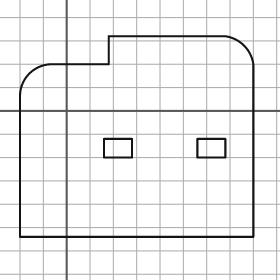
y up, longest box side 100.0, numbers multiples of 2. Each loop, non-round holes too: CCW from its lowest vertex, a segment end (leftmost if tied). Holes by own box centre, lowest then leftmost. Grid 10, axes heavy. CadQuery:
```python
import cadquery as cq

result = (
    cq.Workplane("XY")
    .moveTo(-20.0, -54.0)
    .lineTo(80.0, -54.0)
    .lineTo(80.0, 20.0)
    .threePointArc((76.0, 28.0), (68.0, 32.0))
    .lineTo(18.0, 32.0)
    .lineTo(18.0, 20.0)
    .lineTo(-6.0, 20.0)
    .threePointArc((-16.0, 16.0), (-20.0, 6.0))
    .close()
    .moveTo(16.0, -20.0)
    .lineTo(28.0, -20.0)
    .lineTo(28.0, -12.0)
    .lineTo(16.0, -12.0)
    .close()
    .moveTo(56.0, -20.0)
    .lineTo(68.0, -20.0)
    .lineTo(68.0, -12.0)
    .lineTo(56.0, -12.0)
    .close()
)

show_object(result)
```